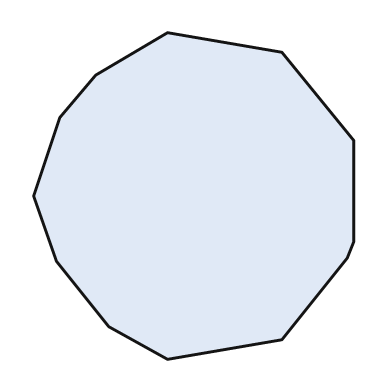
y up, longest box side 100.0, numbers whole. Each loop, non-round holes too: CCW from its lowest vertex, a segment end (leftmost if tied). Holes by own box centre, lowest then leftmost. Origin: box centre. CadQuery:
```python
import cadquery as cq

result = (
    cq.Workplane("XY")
    .moveTo(-8.0, -50.0)
    .lineTo(27.0, -44.0)
    .lineTo(47.0, -19.0)
    .lineTo(49.0, -14.0)
    .lineTo(49.0, 17.0)
    .lineTo(27.0, 44.0)
    .lineTo(-8.0, 50.0)
    .lineTo(-30.0, 37.0)
    .lineTo(-41.0, 24.0)
    .lineTo(-49.0, 0.0)
    .lineTo(-42.0, -20.0)
    .lineTo(-26.0, -40.0)
    .close()
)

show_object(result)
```